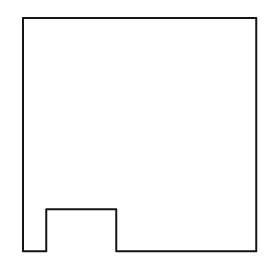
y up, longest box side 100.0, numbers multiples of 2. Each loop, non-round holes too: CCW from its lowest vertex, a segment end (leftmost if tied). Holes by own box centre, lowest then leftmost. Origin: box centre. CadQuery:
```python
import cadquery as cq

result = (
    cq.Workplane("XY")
    .moveTo(-50.0, -50.0)
    .lineTo(-40.0, -50.0)
    .lineTo(-40.0, -32.0)
    .lineTo(-10.0, -32.0)
    .lineTo(-10.0, -50.0)
    .lineTo(50.0, -50.0)
    .lineTo(50.0, 50.0)
    .lineTo(-50.0, 50.0)
    .close()
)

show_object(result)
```